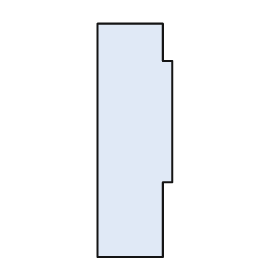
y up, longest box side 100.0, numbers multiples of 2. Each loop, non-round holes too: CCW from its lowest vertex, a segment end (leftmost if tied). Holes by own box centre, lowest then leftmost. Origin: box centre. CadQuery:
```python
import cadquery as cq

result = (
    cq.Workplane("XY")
    .moveTo(-16.0, -50.0)
    .lineTo(12.0, -50.0)
    .lineTo(12.0, -18.0)
    .lineTo(16.0, -18.0)
    .lineTo(16.0, 34.0)
    .lineTo(12.0, 34.0)
    .lineTo(12.0, 50.0)
    .lineTo(-16.0, 50.0)
    .close()
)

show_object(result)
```